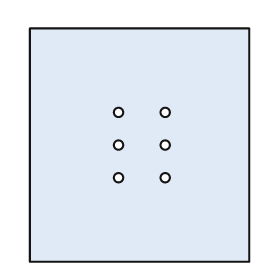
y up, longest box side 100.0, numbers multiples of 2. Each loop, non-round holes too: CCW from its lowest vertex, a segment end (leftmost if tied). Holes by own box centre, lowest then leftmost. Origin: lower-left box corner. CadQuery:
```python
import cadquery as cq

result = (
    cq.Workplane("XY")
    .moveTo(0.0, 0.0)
    .lineTo(94.0, 0.0)
    .lineTo(94.0, 100.0)
    .lineTo(0.0, 100.0)
    .close()
    .moveTo(38.0, 36.0)
    .circle(2.0)
    .moveTo(58.0, 36.0)
    .circle(2.0)
    .moveTo(38.0, 50.0)
    .circle(2.0)
    .moveTo(58.0, 50.0)
    .circle(2.0)
    .moveTo(38.0, 64.0)
    .circle(2.0)
    .moveTo(58.0, 64.0)
    .circle(2.0)
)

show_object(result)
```